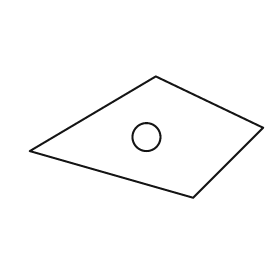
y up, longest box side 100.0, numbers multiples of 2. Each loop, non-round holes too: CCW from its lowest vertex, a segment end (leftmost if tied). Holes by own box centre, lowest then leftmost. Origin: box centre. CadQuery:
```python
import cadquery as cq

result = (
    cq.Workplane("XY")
    .moveTo(20.0, -26.0)
    .lineTo(50.0, 4.0)
    .lineTo(4.0, 26.0)
    .lineTo(-50.0, -6.0)
    .close()
    .moveTo(0.0, 0.0)
    .circle(6.0)
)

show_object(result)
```